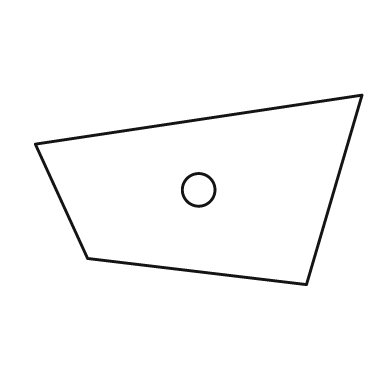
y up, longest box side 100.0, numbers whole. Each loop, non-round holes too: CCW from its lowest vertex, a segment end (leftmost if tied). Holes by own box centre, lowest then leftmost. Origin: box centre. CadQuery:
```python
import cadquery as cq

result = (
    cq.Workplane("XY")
    .moveTo(33.0, -29.0)
    .lineTo(50.0, 29.0)
    .lineTo(-50.0, 14.0)
    .lineTo(-34.0, -21.0)
    .close()
    .moveTo(0.0, 0.0)
    .circle(5.0)
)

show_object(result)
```